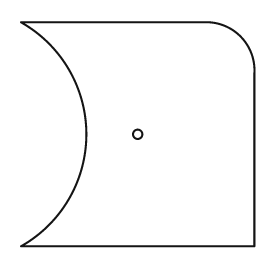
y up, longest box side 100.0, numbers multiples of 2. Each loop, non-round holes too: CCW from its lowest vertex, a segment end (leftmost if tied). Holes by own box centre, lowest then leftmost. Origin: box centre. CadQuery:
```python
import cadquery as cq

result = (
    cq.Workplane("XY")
    .moveTo(-50.0, -48.0)
    .lineTo(50.0, -48.0)
    .lineTo(50.0, 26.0)
    .threePointArc((44.0, 42.0), (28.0, 48.0))
    .lineTo(-50.0, 48.0)
    .threePointArc((-22.0, 0.0), (-50.0, -48.0))
    .close()
    .moveTo(0.0, 0.0)
    .circle(2.0)
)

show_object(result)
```